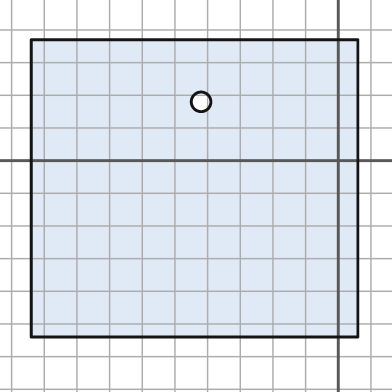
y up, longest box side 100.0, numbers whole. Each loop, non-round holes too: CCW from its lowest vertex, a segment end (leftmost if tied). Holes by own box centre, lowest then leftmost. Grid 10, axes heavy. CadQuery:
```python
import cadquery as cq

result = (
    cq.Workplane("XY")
    .moveTo(-94.0, -54.0)
    .lineTo(6.0, -54.0)
    .lineTo(6.0, 37.0)
    .lineTo(-94.0, 37.0)
    .close()
    .moveTo(-42.0, 18.0)
    .circle(3.0)
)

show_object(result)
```